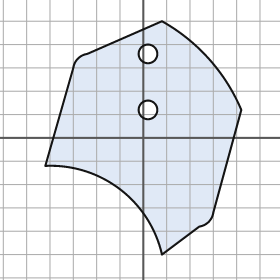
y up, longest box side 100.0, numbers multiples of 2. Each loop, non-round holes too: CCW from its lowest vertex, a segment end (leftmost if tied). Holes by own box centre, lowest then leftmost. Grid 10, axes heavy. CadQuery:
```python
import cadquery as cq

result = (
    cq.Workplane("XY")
    .moveTo(8.0, -50.0)
    .lineTo(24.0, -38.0)
    .threePointArc((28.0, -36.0), (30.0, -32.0))
    .lineTo(42.0, 12.0)
    .threePointArc((28.0, 34.0), (8.0, 50.0))
    .lineTo(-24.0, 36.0)
    .threePointArc((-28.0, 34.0), (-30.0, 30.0))
    .lineTo(-42.0, -12.0)
    .threePointArc((-10.0, -22.0), (8.0, -50.0))
    .close()
    .moveTo(2.0, 12.0)
    .circle(4.0)
    .moveTo(2.0, 36.0)
    .circle(4.0)
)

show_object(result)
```